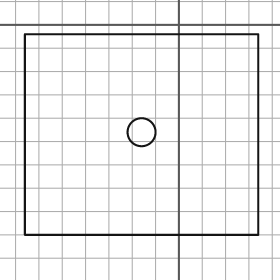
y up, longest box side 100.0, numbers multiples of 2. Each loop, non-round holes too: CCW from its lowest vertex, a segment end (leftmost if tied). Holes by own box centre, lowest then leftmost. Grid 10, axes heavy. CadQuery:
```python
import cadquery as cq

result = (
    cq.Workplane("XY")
    .moveTo(-66.0, -90.0)
    .lineTo(34.0, -90.0)
    .lineTo(34.0, -4.0)
    .lineTo(-66.0, -4.0)
    .close()
    .moveTo(-16.0, -46.0)
    .circle(6.0)
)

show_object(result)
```